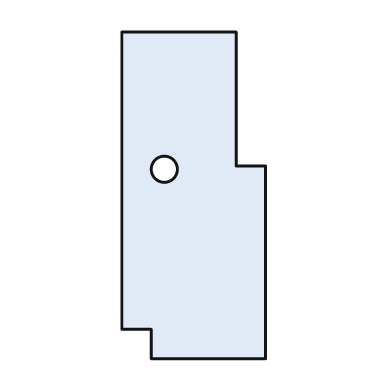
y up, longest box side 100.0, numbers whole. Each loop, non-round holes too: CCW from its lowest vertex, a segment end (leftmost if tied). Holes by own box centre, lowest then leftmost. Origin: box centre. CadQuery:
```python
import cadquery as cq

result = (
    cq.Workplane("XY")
    .moveTo(-13.0, -50.0)
    .lineTo(22.0, -50.0)
    .lineTo(22.0, 9.0)
    .lineTo(13.0, 9.0)
    .lineTo(13.0, 50.0)
    .lineTo(-22.0, 50.0)
    .lineTo(-22.0, -41.0)
    .lineTo(-13.0, -41.0)
    .close()
    .moveTo(-9.0, 8.0)
    .circle(4.0)
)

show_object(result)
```